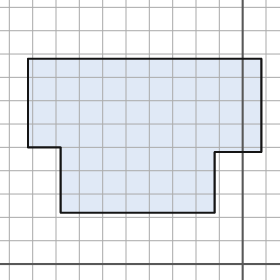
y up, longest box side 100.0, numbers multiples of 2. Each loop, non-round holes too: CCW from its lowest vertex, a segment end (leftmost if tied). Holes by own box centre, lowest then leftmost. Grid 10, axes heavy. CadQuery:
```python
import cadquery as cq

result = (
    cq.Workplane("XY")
    .moveTo(-78.0, 22.0)
    .lineTo(-12.0, 22.0)
    .lineTo(-12.0, 48.0)
    .lineTo(8.0, 48.0)
    .lineTo(8.0, 88.0)
    .lineTo(-92.0, 88.0)
    .lineTo(-92.0, 50.0)
    .lineTo(-78.0, 50.0)
    .close()
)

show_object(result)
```